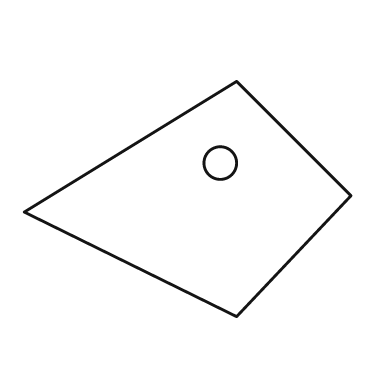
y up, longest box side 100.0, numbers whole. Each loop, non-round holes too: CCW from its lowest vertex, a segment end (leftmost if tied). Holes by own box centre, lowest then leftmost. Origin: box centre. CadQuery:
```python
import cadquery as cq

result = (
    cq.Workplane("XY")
    .moveTo(15.0, -36.0)
    .lineTo(50.0, 1.0)
    .lineTo(15.0, 36.0)
    .lineTo(-50.0, -4.0)
    .close()
    .moveTo(10.0, 11.0)
    .circle(5.0)
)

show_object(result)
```